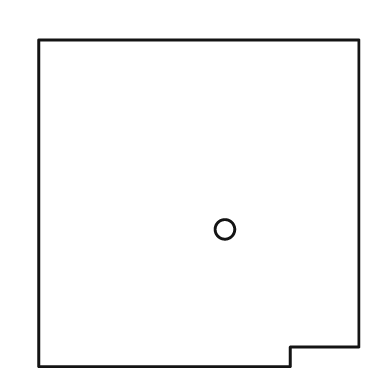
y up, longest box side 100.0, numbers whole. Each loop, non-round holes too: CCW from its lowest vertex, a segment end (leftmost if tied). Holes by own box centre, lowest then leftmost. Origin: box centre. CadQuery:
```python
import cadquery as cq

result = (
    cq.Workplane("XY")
    .moveTo(-49.0, -50.0)
    .lineTo(28.0, -50.0)
    .lineTo(28.0, -44.0)
    .lineTo(49.0, -44.0)
    .lineTo(49.0, 50.0)
    .lineTo(-49.0, 50.0)
    .close()
    .moveTo(8.0, -8.0)
    .circle(3.0)
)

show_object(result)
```